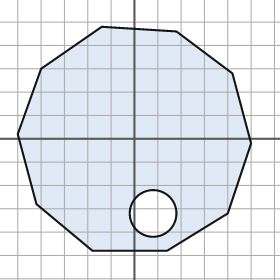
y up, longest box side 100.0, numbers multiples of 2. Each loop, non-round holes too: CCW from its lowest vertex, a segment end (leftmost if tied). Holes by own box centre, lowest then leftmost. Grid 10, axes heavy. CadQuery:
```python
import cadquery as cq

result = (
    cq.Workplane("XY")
    .moveTo(-18.0, -48.0)
    .lineTo(14.0, -48.0)
    .lineTo(40.0, -32.0)
    .lineTo(50.0, -2.0)
    .lineTo(42.0, 28.0)
    .lineTo(18.0, 46.0)
    .lineTo(-14.0, 48.0)
    .lineTo(-40.0, 30.0)
    .lineTo(-50.0, 2.0)
    .lineTo(-42.0, -28.0)
    .close()
    .moveTo(8.0, -32.0)
    .circle(10.0)
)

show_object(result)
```